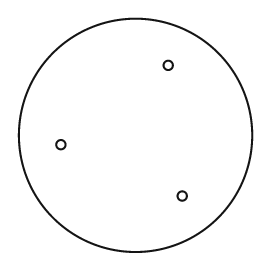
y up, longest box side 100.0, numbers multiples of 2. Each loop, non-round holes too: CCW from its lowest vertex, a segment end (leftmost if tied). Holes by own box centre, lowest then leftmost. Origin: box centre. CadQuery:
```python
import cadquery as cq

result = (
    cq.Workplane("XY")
    .moveTo(0.0, 0.0)
    .circle(50.0)
    .moveTo(20.0, -26.0)
    .circle(2.0)
    .moveTo(-32.0, -4.0)
    .circle(2.0)
    .moveTo(14.0, 30.0)
    .circle(2.0)
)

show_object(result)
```